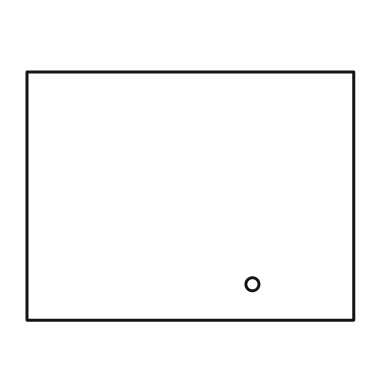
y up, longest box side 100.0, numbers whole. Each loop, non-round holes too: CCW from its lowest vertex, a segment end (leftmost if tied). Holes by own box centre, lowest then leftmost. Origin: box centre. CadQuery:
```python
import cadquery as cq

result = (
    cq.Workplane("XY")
    .moveTo(-50.0, -38.0)
    .lineTo(50.0, -38.0)
    .lineTo(50.0, 38.0)
    .lineTo(-50.0, 38.0)
    .close()
    .moveTo(19.0, -27.0)
    .circle(2.0)
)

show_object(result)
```